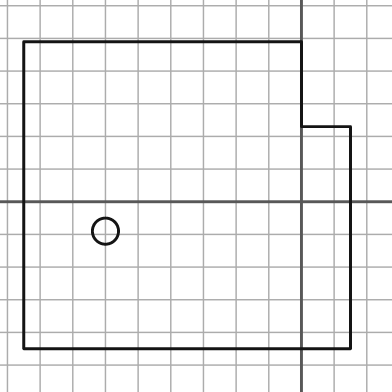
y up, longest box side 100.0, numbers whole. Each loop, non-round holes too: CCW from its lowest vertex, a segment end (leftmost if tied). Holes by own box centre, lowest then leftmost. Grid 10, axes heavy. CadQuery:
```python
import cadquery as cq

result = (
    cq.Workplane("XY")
    .moveTo(-85.0, -45.0)
    .lineTo(15.0, -45.0)
    .lineTo(15.0, 23.0)
    .lineTo(0.0, 23.0)
    .lineTo(0.0, 49.0)
    .lineTo(-85.0, 49.0)
    .close()
    .moveTo(-60.0, -9.0)
    .circle(4.0)
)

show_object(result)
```